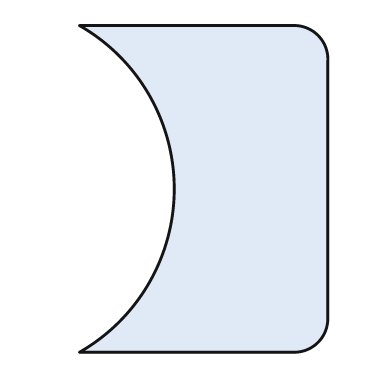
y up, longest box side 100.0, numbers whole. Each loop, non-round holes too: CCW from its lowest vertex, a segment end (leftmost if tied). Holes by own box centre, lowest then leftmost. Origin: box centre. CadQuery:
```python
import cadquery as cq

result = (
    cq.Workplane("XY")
    .moveTo(-38.0, -50.0)
    .lineTo(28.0, -50.0)
    .threePointArc((35.0, -47.0), (38.0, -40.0))
    .lineTo(38.0, 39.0)
    .threePointArc((35.0, 47.0), (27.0, 50.0))
    .lineTo(-38.0, 50.0)
    .threePointArc((-9.0, 0.0), (-38.0, -50.0))
    .close()
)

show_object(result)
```